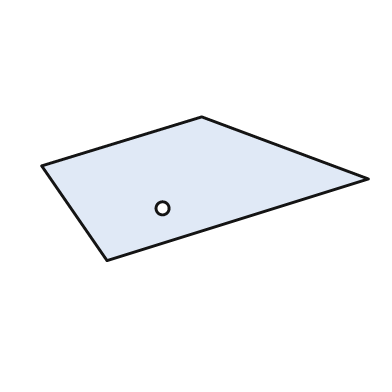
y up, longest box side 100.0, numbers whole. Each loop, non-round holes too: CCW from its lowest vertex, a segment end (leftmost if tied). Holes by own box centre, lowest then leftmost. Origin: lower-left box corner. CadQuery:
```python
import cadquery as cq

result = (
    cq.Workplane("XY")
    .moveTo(20.0, 0.0)
    .lineTo(100.0, 25.0)
    .lineTo(49.0, 44.0)
    .lineTo(0.0, 29.0)
    .close()
    .moveTo(37.0, 16.0)
    .circle(2.0)
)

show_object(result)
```